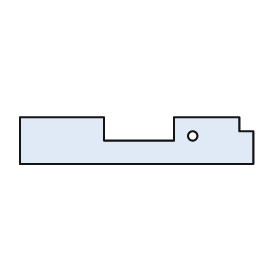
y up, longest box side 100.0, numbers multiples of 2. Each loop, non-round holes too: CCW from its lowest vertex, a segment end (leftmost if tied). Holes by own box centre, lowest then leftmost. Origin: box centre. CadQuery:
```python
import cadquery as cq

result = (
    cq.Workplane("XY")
    .moveTo(-50.0, -10.0)
    .lineTo(50.0, -10.0)
    .lineTo(50.0, 4.0)
    .lineTo(44.0, 4.0)
    .lineTo(44.0, 10.0)
    .lineTo(16.0, 10.0)
    .lineTo(16.0, 0.0)
    .lineTo(-14.0, 0.0)
    .lineTo(-14.0, 10.0)
    .lineTo(-50.0, 10.0)
    .close()
    .moveTo(24.0, 2.0)
    .circle(2.0)
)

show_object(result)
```